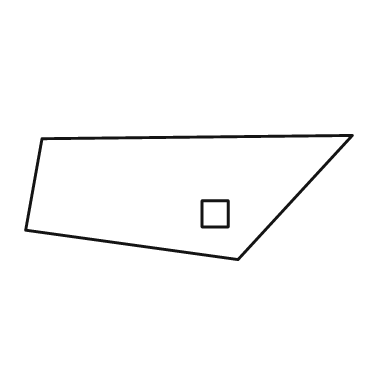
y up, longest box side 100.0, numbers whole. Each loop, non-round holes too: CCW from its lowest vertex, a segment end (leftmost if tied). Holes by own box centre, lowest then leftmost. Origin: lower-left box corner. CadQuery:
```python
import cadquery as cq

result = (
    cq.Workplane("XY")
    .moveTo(65.0, 0.0)
    .lineTo(100.0, 38.0)
    .lineTo(5.0, 37.0)
    .lineTo(0.0, 9.0)
    .close()
    .moveTo(54.0, 10.0)
    .lineTo(62.0, 10.0)
    .lineTo(62.0, 18.0)
    .lineTo(54.0, 18.0)
    .close()
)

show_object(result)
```